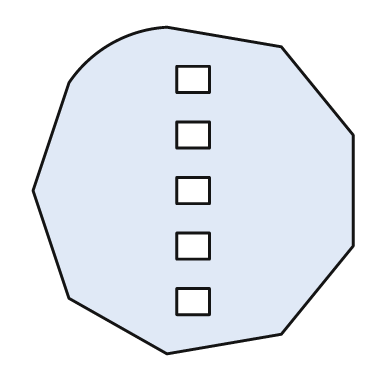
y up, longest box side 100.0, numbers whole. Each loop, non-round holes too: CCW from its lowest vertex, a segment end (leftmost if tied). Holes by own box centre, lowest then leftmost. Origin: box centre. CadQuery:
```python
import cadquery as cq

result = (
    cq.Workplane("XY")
    .moveTo(-8.0, -50.0)
    .lineTo(27.0, -44.0)
    .lineTo(49.0, -17.0)
    .lineTo(49.0, 17.0)
    .lineTo(27.0, 44.0)
    .lineTo(-8.0, 50.0)
    .threePointArc((-25.0, 45.0), (-38.0, 33.0))
    .lineTo(-49.0, 0.0)
    .lineTo(-38.0, -33.0)
    .close()
    .moveTo(-5.0, -38.0)
    .lineTo(5.0, -38.0)
    .lineTo(5.0, -30.0)
    .lineTo(-5.0, -30.0)
    .close()
    .moveTo(-5.0, -21.0)
    .lineTo(5.0, -21.0)
    .lineTo(5.0, -13.0)
    .lineTo(-5.0, -13.0)
    .close()
    .moveTo(-5.0, -4.0)
    .lineTo(5.0, -4.0)
    .lineTo(5.0, 4.0)
    .lineTo(-5.0, 4.0)
    .close()
    .moveTo(-5.0, 13.0)
    .lineTo(5.0, 13.0)
    .lineTo(5.0, 21.0)
    .lineTo(-5.0, 21.0)
    .close()
    .moveTo(-5.0, 30.0)
    .lineTo(5.0, 30.0)
    .lineTo(5.0, 38.0)
    .lineTo(-5.0, 38.0)
    .close()
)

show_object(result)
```